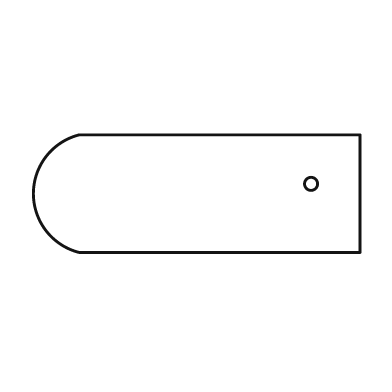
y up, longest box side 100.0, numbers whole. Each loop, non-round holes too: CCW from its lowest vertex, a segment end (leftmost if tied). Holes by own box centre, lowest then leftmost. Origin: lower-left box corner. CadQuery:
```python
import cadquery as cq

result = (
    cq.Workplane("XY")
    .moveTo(14.0, 0.0)
    .lineTo(100.0, 0.0)
    .lineTo(100.0, 36.0)
    .lineTo(14.0, 36.0)
    .threePointArc((0.0, 18.0), (14.0, 0.0))
    .close()
    .moveTo(85.0, 21.0)
    .circle(2.0)
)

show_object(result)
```